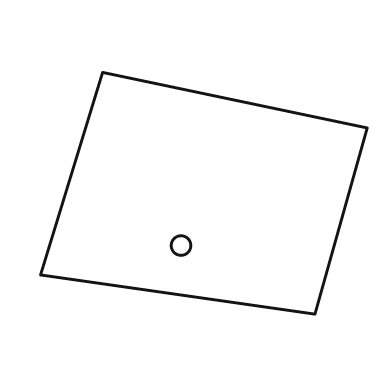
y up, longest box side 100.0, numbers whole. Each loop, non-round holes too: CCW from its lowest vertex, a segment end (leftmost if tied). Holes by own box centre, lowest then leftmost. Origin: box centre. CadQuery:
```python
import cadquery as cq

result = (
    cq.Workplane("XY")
    .moveTo(34.0, -37.0)
    .lineTo(50.0, 20.0)
    .lineTo(-31.0, 37.0)
    .lineTo(-50.0, -25.0)
    .close()
    .moveTo(-7.0, -16.0)
    .circle(3.0)
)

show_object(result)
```